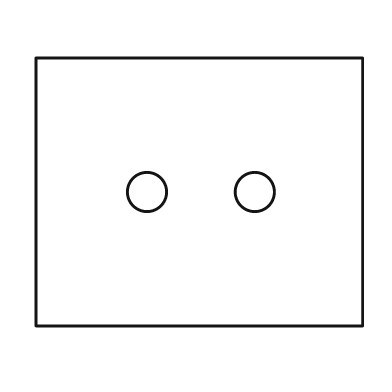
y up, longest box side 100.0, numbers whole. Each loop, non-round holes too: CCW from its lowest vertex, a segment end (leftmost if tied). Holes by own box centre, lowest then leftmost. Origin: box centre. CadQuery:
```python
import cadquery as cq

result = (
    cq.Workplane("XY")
    .moveTo(-50.0, -41.0)
    .lineTo(50.0, -41.0)
    .lineTo(50.0, 41.0)
    .lineTo(-50.0, 41.0)
    .close()
    .moveTo(-16.0, 0.0)
    .circle(6.0)
    .moveTo(17.0, 0.0)
    .circle(6.0)
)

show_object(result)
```